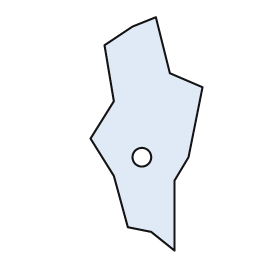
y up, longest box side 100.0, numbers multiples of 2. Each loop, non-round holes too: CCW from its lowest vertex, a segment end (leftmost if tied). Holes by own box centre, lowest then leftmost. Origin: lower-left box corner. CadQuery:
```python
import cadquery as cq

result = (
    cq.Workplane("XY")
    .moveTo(36.0, 0.0)
    .lineTo(36.0, 30.0)
    .lineTo(42.0, 40.0)
    .lineTo(48.0, 70.0)
    .lineTo(34.0, 76.0)
    .lineTo(28.0, 100.0)
    .lineTo(18.0, 96.0)
    .lineTo(6.0, 88.0)
    .lineTo(10.0, 64.0)
    .lineTo(0.0, 48.0)
    .lineTo(10.0, 32.0)
    .lineTo(16.0, 10.0)
    .lineTo(26.0, 8.0)
    .close()
    .moveTo(22.0, 40.0)
    .circle(4.0)
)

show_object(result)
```